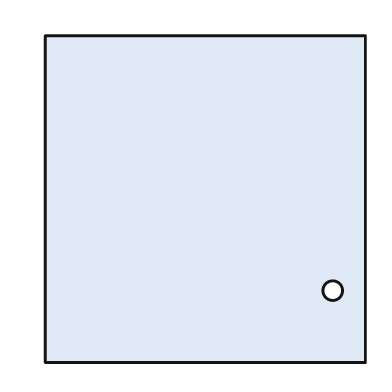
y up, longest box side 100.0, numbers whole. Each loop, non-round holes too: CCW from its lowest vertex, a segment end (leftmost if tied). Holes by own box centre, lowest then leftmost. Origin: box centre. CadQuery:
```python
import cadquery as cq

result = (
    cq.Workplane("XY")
    .moveTo(-49.0, -50.0)
    .lineTo(49.0, -50.0)
    .lineTo(49.0, 50.0)
    .lineTo(-49.0, 50.0)
    .close()
    .moveTo(39.0, -28.0)
    .circle(3.0)
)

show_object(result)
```